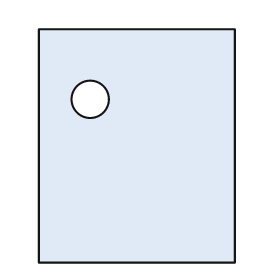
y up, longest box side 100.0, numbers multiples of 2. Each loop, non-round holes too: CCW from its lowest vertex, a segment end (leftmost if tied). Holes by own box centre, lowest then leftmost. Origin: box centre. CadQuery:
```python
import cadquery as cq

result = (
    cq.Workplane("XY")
    .moveTo(-42.0, -50.0)
    .lineTo(42.0, -50.0)
    .lineTo(42.0, 50.0)
    .lineTo(-42.0, 50.0)
    .close()
    .moveTo(-20.0, 20.0)
    .circle(8.0)
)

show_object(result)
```